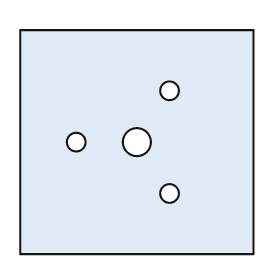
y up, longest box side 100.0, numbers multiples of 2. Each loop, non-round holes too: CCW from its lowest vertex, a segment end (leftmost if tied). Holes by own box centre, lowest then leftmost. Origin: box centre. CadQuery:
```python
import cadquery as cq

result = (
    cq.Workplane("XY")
    .moveTo(-50.0, -48.0)
    .lineTo(50.0, -48.0)
    .lineTo(50.0, 48.0)
    .lineTo(-50.0, 48.0)
    .close()
    .moveTo(14.0, -22.0)
    .circle(4.0)
    .moveTo(-26.0, 0.0)
    .circle(4.0)
    .moveTo(0.0, 0.0)
    .circle(6.0)
    .moveTo(14.0, 22.0)
    .circle(4.0)
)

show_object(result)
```